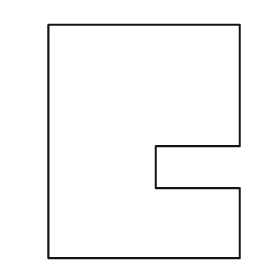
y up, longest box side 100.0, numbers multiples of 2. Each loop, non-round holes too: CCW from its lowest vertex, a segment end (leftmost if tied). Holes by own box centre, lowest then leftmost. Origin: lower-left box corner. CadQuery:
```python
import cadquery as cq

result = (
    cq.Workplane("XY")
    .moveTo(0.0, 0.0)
    .lineTo(82.0, 0.0)
    .lineTo(82.0, 30.0)
    .lineTo(46.0, 30.0)
    .lineTo(46.0, 48.0)
    .lineTo(82.0, 48.0)
    .lineTo(82.0, 100.0)
    .lineTo(0.0, 100.0)
    .close()
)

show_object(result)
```